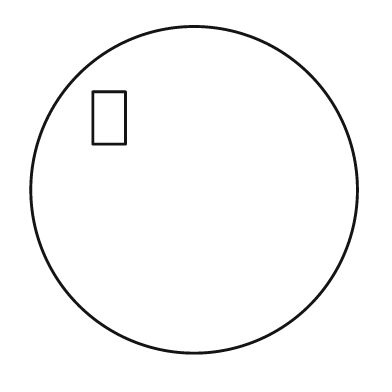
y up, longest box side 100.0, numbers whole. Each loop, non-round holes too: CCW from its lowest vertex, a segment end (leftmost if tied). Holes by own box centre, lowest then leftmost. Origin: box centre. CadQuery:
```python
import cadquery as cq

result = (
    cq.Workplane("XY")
    .moveTo(0.0, 0.0)
    .circle(50.0)
    .moveTo(-31.0, 14.0)
    .lineTo(-21.0, 14.0)
    .lineTo(-21.0, 30.0)
    .lineTo(-31.0, 30.0)
    .close()
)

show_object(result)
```